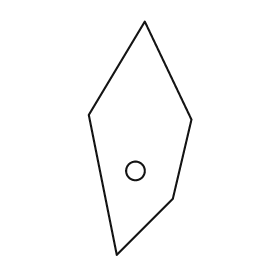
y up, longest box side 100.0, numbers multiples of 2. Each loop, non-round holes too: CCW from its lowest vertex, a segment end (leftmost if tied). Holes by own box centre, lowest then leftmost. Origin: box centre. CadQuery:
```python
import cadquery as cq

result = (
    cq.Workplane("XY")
    .moveTo(-10.0, -50.0)
    .lineTo(14.0, -26.0)
    .lineTo(22.0, 8.0)
    .lineTo(2.0, 50.0)
    .lineTo(-22.0, 10.0)
    .close()
    .moveTo(-2.0, -14.0)
    .circle(4.0)
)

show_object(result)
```